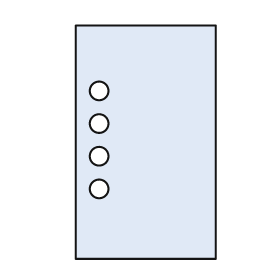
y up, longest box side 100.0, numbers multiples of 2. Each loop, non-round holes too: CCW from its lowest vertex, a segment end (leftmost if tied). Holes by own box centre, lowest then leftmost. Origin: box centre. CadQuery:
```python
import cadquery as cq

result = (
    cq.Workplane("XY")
    .moveTo(-30.0, -50.0)
    .lineTo(30.0, -50.0)
    .lineTo(30.0, 50.0)
    .lineTo(-30.0, 50.0)
    .close()
    .moveTo(-20.0, -20.0)
    .circle(4.0)
    .moveTo(-20.0, -6.0)
    .circle(4.0)
    .moveTo(-20.0, 8.0)
    .circle(4.0)
    .moveTo(-20.0, 22.0)
    .circle(4.0)
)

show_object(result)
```